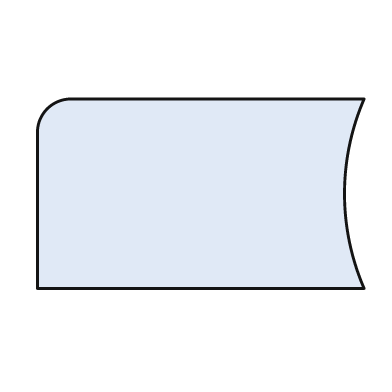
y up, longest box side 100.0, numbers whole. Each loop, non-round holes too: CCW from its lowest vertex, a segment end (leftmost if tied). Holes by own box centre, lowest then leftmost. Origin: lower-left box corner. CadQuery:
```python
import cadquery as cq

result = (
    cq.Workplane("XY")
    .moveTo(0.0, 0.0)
    .lineTo(100.0, 0.0)
    .threePointArc((94.0, 29.0), (100.0, 58.0))
    .lineTo(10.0, 58.0)
    .threePointArc((3.0, 55.0), (0.0, 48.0))
    .close()
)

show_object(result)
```